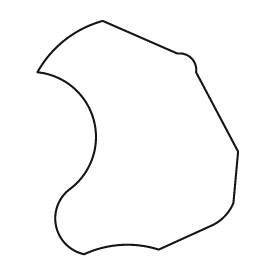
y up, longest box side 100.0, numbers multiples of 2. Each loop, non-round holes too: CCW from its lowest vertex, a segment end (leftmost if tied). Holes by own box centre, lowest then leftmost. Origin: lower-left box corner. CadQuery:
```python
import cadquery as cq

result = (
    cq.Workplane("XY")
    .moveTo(20.0, 0.0)
    .threePointArc((36.0, 4.0), (52.0, 2.0))
    .lineTo(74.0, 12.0)
    .threePointArc((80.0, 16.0), (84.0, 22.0))
    .lineTo(86.0, 44.0)
    .lineTo(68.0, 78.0)
    .threePointArc((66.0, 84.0), (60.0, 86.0))
    .lineTo(28.0, 100.0)
    .threePointArc((12.0, 92.0), (0.0, 78.0))
    .threePointArc((24.0, 58.0), (14.0, 28.0))
    .threePointArc((8.0, 12.0), (20.0, 0.0))
    .close()
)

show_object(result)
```